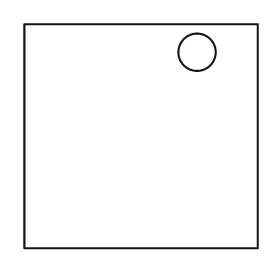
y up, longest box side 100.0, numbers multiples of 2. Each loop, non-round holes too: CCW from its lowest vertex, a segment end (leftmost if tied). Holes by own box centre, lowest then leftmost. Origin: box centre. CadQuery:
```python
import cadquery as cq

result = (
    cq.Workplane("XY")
    .moveTo(-50.0, -48.0)
    .lineTo(50.0, -48.0)
    .lineTo(50.0, 48.0)
    .lineTo(-50.0, 48.0)
    .close()
    .moveTo(24.0, 36.0)
    .circle(8.0)
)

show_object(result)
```